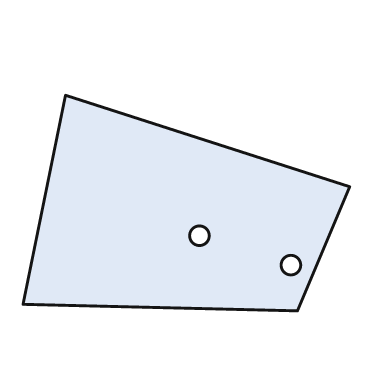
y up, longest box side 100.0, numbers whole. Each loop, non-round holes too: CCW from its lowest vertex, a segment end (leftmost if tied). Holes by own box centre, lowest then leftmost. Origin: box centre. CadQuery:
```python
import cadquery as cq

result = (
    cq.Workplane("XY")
    .moveTo(34.0, -33.0)
    .lineTo(50.0, 5.0)
    .lineTo(-37.0, 33.0)
    .lineTo(-50.0, -31.0)
    .close()
    .moveTo(32.0, -19.0)
    .circle(3.0)
    .moveTo(4.0, -10.0)
    .circle(3.0)
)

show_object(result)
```